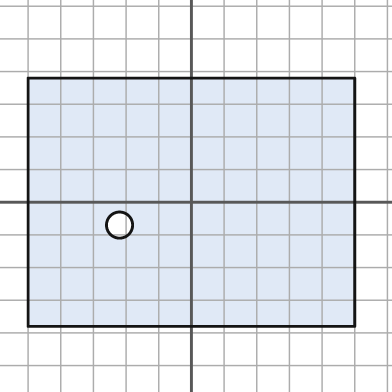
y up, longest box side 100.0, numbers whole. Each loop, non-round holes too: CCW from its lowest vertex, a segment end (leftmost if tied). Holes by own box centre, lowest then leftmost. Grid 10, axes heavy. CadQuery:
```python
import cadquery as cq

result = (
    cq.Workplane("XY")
    .moveTo(-50.0, -38.0)
    .lineTo(50.0, -38.0)
    .lineTo(50.0, 38.0)
    .lineTo(-50.0, 38.0)
    .close()
    .moveTo(-22.0, -7.0)
    .circle(4.0)
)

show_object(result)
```